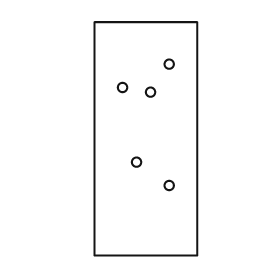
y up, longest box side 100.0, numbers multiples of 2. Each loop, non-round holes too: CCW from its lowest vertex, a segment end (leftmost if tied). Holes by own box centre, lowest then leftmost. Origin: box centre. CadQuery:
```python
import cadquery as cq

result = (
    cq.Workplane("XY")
    .moveTo(-22.0, -50.0)
    .lineTo(22.0, -50.0)
    .lineTo(22.0, 50.0)
    .lineTo(-22.0, 50.0)
    .close()
    .moveTo(10.0, -20.0)
    .circle(2.0)
    .moveTo(-4.0, -10.0)
    .circle(2.0)
    .moveTo(2.0, 20.0)
    .circle(2.0)
    .moveTo(-10.0, 22.0)
    .circle(2.0)
    .moveTo(10.0, 32.0)
    .circle(2.0)
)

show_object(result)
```